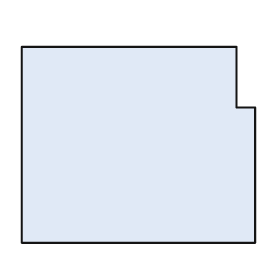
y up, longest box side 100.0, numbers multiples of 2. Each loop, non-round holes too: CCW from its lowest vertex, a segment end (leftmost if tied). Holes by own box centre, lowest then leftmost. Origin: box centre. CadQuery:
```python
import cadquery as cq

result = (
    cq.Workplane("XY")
    .moveTo(-50.0, -42.0)
    .lineTo(50.0, -42.0)
    .lineTo(50.0, 16.0)
    .lineTo(42.0, 16.0)
    .lineTo(42.0, 42.0)
    .lineTo(-50.0, 42.0)
    .close()
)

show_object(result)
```